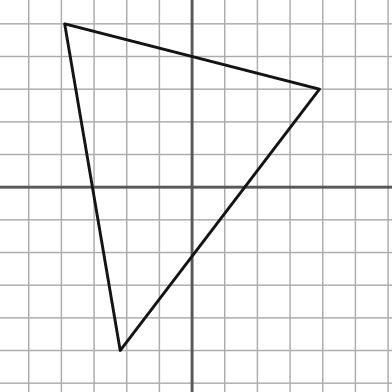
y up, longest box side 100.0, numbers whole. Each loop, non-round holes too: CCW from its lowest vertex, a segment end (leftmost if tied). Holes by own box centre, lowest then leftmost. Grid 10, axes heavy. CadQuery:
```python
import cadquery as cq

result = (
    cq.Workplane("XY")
    .moveTo(-22.0, -50.0)
    .lineTo(39.0, 30.0)
    .lineTo(-39.0, 50.0)
    .close()
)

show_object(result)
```